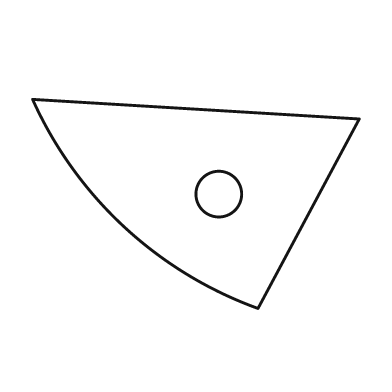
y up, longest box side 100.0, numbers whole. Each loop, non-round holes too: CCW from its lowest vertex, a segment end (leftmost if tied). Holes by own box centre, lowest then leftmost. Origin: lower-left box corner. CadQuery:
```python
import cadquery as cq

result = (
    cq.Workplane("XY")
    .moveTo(69.0, 0.0)
    .lineTo(100.0, 58.0)
    .lineTo(0.0, 64.0)
    .threePointArc((28.0, 25.0), (69.0, 0.0))
    .close()
    .moveTo(57.0, 35.0)
    .circle(7.0)
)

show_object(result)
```